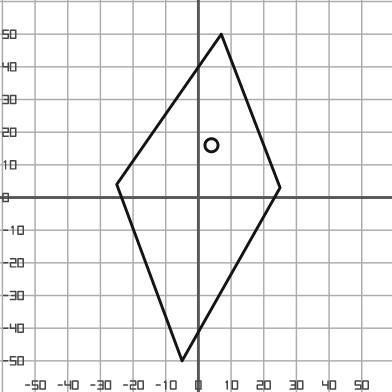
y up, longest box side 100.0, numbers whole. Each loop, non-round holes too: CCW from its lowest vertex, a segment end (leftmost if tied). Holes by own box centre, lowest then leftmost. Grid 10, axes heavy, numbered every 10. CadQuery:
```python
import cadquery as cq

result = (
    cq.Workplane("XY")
    .moveTo(-5.0, -50.0)
    .lineTo(25.0, 3.0)
    .lineTo(7.0, 50.0)
    .lineTo(-25.0, 4.0)
    .close()
    .moveTo(4.0, 16.0)
    .circle(2.0)
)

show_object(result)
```